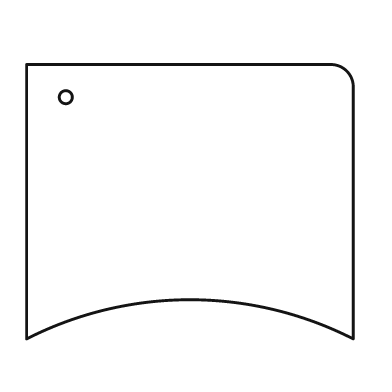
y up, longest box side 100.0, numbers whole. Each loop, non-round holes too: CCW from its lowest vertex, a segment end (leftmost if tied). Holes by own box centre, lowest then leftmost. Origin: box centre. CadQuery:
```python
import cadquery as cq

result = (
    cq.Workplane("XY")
    .moveTo(-50.0, -42.0)
    .threePointArc((0.0, -30.0), (50.0, -42.0))
    .lineTo(50.0, 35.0)
    .threePointArc((48.0, 40.0), (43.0, 42.0))
    .lineTo(-50.0, 42.0)
    .close()
    .moveTo(-38.0, 32.0)
    .circle(2.0)
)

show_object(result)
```